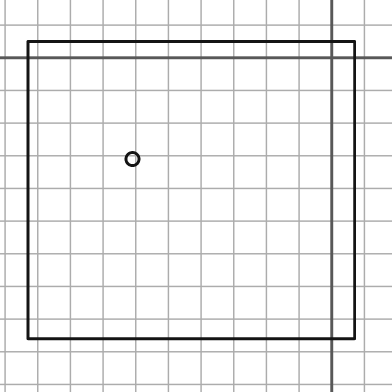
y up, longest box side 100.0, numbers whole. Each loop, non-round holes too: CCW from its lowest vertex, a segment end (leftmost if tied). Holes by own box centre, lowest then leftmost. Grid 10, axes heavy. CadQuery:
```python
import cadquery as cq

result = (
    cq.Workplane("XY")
    .moveTo(-93.0, -86.0)
    .lineTo(7.0, -86.0)
    .lineTo(7.0, 5.0)
    .lineTo(-93.0, 5.0)
    .close()
    .moveTo(-61.0, -31.0)
    .circle(2.0)
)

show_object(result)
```